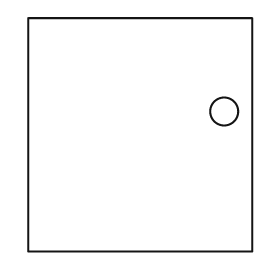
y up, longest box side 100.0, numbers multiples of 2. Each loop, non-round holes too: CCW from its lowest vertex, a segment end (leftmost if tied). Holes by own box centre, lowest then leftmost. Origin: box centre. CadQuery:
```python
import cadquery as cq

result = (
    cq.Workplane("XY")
    .moveTo(-48.0, -50.0)
    .lineTo(48.0, -50.0)
    .lineTo(48.0, 50.0)
    .lineTo(-48.0, 50.0)
    .close()
    .moveTo(36.0, 10.0)
    .circle(6.0)
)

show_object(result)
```